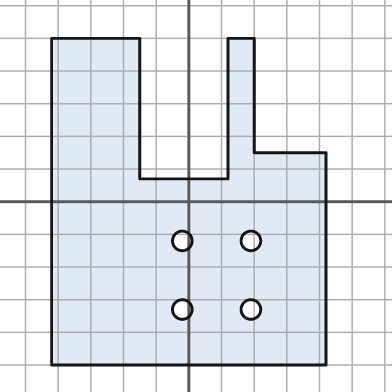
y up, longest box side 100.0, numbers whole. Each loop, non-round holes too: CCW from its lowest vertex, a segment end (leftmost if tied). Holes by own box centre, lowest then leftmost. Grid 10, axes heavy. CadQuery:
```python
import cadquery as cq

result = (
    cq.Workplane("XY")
    .moveTo(-42.0, -50.0)
    .lineTo(42.0, -50.0)
    .lineTo(42.0, 15.0)
    .lineTo(20.0, 15.0)
    .lineTo(20.0, 50.0)
    .lineTo(12.0, 50.0)
    .lineTo(12.0, 7.0)
    .lineTo(-15.0, 7.0)
    .lineTo(-15.0, 50.0)
    .lineTo(-42.0, 50.0)
    .close()
    .moveTo(-2.0, -33.0)
    .circle(3.0)
    .moveTo(19.0, -33.0)
    .circle(3.0)
    .moveTo(-2.0, -12.0)
    .circle(3.0)
    .moveTo(19.0, -12.0)
    .circle(3.0)
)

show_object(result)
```